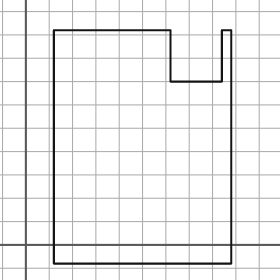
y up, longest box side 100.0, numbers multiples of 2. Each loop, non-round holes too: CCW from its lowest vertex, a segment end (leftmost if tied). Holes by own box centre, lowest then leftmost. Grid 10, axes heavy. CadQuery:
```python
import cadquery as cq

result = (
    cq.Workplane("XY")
    .moveTo(12.0, -8.0)
    .lineTo(88.0, -8.0)
    .lineTo(88.0, 92.0)
    .lineTo(84.0, 92.0)
    .lineTo(84.0, 70.0)
    .lineTo(62.0, 70.0)
    .lineTo(62.0, 92.0)
    .lineTo(12.0, 92.0)
    .close()
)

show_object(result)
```